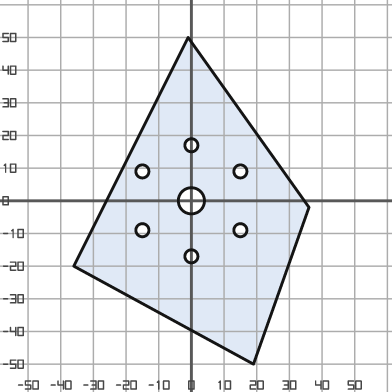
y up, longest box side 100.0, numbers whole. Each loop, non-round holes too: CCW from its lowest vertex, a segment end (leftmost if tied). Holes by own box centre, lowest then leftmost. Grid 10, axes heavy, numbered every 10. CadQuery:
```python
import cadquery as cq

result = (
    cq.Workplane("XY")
    .moveTo(19.0, -50.0)
    .lineTo(36.0, -2.0)
    .lineTo(-1.0, 50.0)
    .lineTo(-36.0, -20.0)
    .close()
    .moveTo(0.0, -17.0)
    .circle(2.0)
    .moveTo(-15.0, -9.0)
    .circle(2.0)
    .moveTo(15.0, -9.0)
    .circle(2.0)
    .moveTo(0.0, 0.0)
    .circle(4.0)
    .moveTo(-15.0, 9.0)
    .circle(2.0)
    .moveTo(15.0, 9.0)
    .circle(2.0)
    .moveTo(0.0, 17.0)
    .circle(2.0)
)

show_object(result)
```